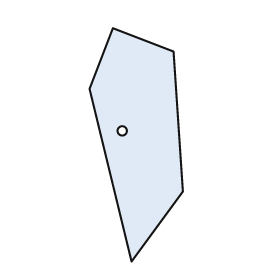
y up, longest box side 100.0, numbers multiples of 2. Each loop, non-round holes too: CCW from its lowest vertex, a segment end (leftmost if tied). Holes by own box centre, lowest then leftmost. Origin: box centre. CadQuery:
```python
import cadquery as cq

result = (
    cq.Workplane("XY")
    .moveTo(-2.0, -50.0)
    .lineTo(20.0, -20.0)
    .lineTo(16.0, 40.0)
    .lineTo(-10.0, 50.0)
    .lineTo(-20.0, 24.0)
    .close()
    .moveTo(-6.0, 6.0)
    .circle(2.0)
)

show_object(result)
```